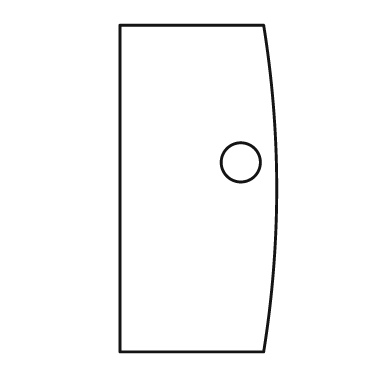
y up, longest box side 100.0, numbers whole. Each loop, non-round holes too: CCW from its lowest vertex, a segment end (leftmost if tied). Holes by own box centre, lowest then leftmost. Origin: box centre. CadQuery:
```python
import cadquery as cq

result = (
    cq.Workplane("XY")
    .moveTo(-24.0, -50.0)
    .lineTo(20.0, -50.0)
    .threePointArc((24.0, 0.0), (20.0, 50.0))
    .lineTo(-24.0, 50.0)
    .close()
    .moveTo(13.0, 8.0)
    .circle(6.0)
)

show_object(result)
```